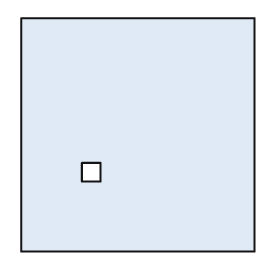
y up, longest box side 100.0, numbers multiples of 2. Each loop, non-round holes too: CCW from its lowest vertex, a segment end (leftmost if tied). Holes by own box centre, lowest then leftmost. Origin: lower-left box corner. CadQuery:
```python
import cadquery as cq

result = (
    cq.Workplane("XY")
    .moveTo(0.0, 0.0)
    .lineTo(100.0, 0.0)
    .lineTo(100.0, 100.0)
    .lineTo(0.0, 100.0)
    .close()
    .moveTo(26.0, 30.0)
    .lineTo(34.0, 30.0)
    .lineTo(34.0, 38.0)
    .lineTo(26.0, 38.0)
    .close()
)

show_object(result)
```